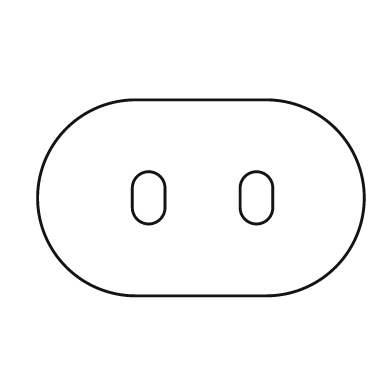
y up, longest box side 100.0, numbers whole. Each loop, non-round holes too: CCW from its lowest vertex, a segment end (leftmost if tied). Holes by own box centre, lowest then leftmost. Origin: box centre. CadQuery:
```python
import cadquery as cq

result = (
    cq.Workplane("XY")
    .moveTo(-20.0, -30.0)
    .lineTo(20.0, -30.0)
    .threePointArc((50.0, 0.0), (20.0, 30.0))
    .lineTo(-20.0, 30.0)
    .threePointArc((-50.0, 0.0), (-20.0, -30.0))
    .close()
    .moveTo(-21.0, -3.0)
    .threePointArc((-16.0, -8.0), (-11.0, -3.0))
    .lineTo(-11.0, 3.0)
    .threePointArc((-16.0, 8.0), (-21.0, 3.0))
    .close()
    .moveTo(12.0, -3.0)
    .threePointArc((17.0, -8.0), (22.0, -3.0))
    .lineTo(22.0, 3.0)
    .threePointArc((17.0, 8.0), (12.0, 3.0))
    .close()
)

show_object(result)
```